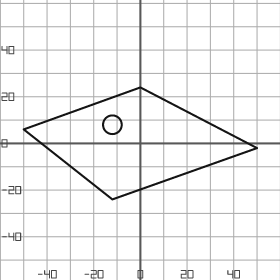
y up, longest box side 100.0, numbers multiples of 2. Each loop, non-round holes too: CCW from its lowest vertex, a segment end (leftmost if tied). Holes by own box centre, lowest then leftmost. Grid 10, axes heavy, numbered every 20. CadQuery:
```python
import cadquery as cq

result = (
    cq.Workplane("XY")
    .moveTo(-12.0, -24.0)
    .lineTo(50.0, -2.0)
    .lineTo(0.0, 24.0)
    .lineTo(-50.0, 6.0)
    .close()
    .moveTo(-12.0, 8.0)
    .circle(4.0)
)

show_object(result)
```